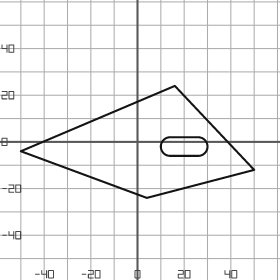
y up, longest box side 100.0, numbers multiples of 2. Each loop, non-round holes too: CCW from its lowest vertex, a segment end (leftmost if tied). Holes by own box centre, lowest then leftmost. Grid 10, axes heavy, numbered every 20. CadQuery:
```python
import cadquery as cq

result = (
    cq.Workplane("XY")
    .moveTo(4.0, -24.0)
    .lineTo(50.0, -12.0)
    .lineTo(16.0, 24.0)
    .lineTo(-50.0, -4.0)
    .close()
    .moveTo(14.0, -6.0)
    .lineTo(26.0, -6.0)
    .threePointArc((30.0, -2.0), (26.0, 2.0))
    .lineTo(14.0, 2.0)
    .threePointArc((10.0, -2.0), (14.0, -6.0))
    .close()
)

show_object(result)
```